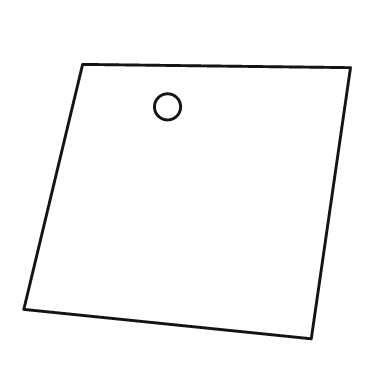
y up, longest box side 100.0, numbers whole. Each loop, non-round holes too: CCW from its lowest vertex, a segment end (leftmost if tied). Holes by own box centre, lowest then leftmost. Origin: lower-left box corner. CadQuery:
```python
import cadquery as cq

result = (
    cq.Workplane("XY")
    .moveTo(88.0, 0.0)
    .lineTo(100.0, 83.0)
    .lineTo(18.0, 84.0)
    .lineTo(0.0, 9.0)
    .close()
    .moveTo(44.0, 71.0)
    .circle(4.0)
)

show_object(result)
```